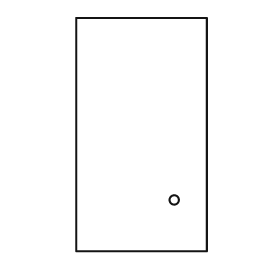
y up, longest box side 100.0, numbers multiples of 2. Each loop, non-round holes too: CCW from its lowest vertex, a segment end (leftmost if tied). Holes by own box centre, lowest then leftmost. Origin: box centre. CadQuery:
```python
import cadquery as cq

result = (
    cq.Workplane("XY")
    .moveTo(-28.0, -50.0)
    .lineTo(28.0, -50.0)
    .lineTo(28.0, 50.0)
    .lineTo(-28.0, 50.0)
    .close()
    .moveTo(14.0, -28.0)
    .circle(2.0)
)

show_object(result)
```